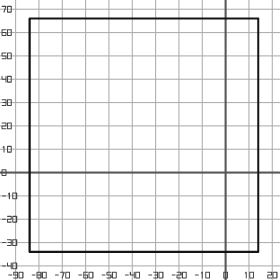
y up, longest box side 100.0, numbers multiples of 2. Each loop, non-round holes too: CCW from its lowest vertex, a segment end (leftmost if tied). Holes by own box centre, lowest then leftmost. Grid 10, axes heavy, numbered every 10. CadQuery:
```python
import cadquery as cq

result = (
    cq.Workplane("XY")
    .moveTo(-84.0, -34.0)
    .lineTo(14.0, -34.0)
    .lineTo(14.0, 66.0)
    .lineTo(-84.0, 66.0)
    .close()
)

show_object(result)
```